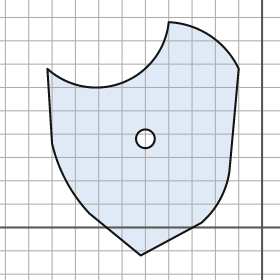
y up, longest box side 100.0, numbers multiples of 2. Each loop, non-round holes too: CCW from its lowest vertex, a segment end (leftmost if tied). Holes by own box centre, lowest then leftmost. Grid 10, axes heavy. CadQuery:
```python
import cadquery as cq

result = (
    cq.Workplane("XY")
    .moveTo(-52.0, -12.0)
    .lineTo(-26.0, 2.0)
    .threePointArc((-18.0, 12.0), (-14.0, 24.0))
    .lineTo(-10.0, 68.0)
    .threePointArc((-22.0, 82.0), (-40.0, 88.0))
    .threePointArc((-60.0, 62.0), (-92.0, 68.0))
    .lineTo(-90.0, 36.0)
    .threePointArc((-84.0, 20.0), (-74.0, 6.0))
    .close()
    .moveTo(-50.0, 38.0)
    .circle(4.0)
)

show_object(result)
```